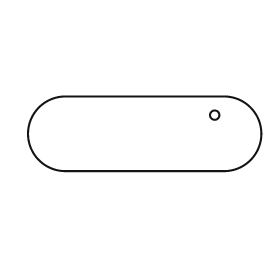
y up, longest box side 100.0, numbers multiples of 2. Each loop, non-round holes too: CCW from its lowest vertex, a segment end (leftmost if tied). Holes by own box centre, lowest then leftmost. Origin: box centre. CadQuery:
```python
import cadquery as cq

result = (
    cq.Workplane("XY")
    .moveTo(-34.0, -16.0)
    .lineTo(34.0, -16.0)
    .threePointArc((50.0, 0.0), (34.0, 16.0))
    .lineTo(-34.0, 16.0)
    .threePointArc((-50.0, 0.0), (-34.0, -16.0))
    .close()
    .moveTo(30.0, 8.0)
    .circle(2.0)
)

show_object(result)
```